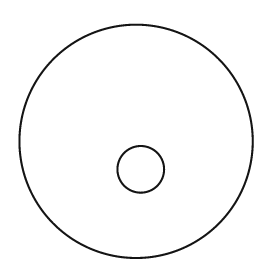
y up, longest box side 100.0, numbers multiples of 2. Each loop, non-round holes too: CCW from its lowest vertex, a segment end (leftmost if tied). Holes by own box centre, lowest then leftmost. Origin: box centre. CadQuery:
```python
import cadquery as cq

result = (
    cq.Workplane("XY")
    .moveTo(0.0, 0.0)
    .circle(50.0)
    .moveTo(2.0, -12.0)
    .circle(10.0)
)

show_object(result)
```